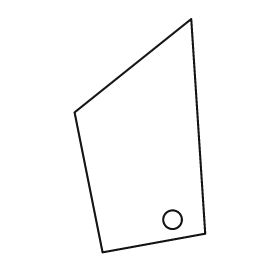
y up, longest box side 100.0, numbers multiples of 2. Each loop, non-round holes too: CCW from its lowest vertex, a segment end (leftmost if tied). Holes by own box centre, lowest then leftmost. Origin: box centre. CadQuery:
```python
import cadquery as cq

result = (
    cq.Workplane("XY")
    .moveTo(-16.0, -50.0)
    .lineTo(28.0, -42.0)
    .lineTo(22.0, 50.0)
    .lineTo(-28.0, 10.0)
    .close()
    .moveTo(14.0, -36.0)
    .circle(4.0)
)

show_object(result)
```